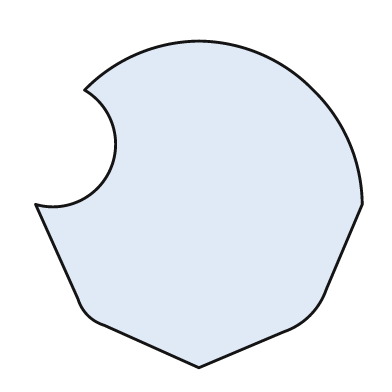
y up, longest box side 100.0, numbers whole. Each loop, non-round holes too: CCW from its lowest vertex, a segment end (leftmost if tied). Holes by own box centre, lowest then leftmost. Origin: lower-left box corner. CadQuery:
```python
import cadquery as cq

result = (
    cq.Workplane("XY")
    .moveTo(50.0, 0.0)
    .lineTo(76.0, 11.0)
    .threePointArc((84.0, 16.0), (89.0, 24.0))
    .lineTo(100.0, 50.0)
    .threePointArc((96.0, 69.0), (85.0, 85.0))
    .threePointArc((69.0, 96.0), (50.0, 100.0))
    .threePointArc((31.0, 96.0), (15.0, 85.0))
    .threePointArc((23.0, 61.0), (0.0, 50.0))
    .lineTo(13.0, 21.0)
    .threePointArc((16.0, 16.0), (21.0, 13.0))
    .close()
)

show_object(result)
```